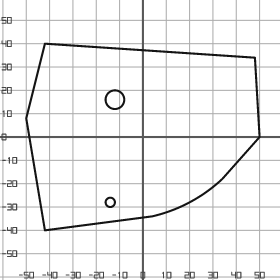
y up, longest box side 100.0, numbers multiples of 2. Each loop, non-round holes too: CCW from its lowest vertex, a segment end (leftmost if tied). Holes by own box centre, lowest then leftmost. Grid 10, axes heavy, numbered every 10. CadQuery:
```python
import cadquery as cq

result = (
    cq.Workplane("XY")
    .moveTo(-42.0, -40.0)
    .lineTo(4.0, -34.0)
    .threePointArc((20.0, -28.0), (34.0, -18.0))
    .lineTo(50.0, 0.0)
    .lineTo(48.0, 34.0)
    .lineTo(-42.0, 40.0)
    .lineTo(-50.0, 8.0)
    .close()
    .moveTo(-14.0, -28.0)
    .circle(2.0)
    .moveTo(-12.0, 16.0)
    .circle(4.0)
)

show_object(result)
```